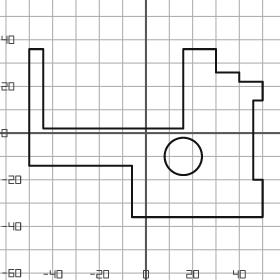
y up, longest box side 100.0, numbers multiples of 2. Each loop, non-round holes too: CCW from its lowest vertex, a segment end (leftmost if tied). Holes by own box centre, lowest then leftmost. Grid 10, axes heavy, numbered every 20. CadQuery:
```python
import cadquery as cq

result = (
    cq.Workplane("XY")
    .moveTo(-6.0, -36.0)
    .lineTo(50.0, -36.0)
    .lineTo(50.0, -20.0)
    .lineTo(46.0, -20.0)
    .lineTo(46.0, 14.0)
    .lineTo(50.0, 14.0)
    .lineTo(50.0, 22.0)
    .lineTo(40.0, 22.0)
    .lineTo(40.0, 26.0)
    .lineTo(30.0, 26.0)
    .lineTo(30.0, 36.0)
    .lineTo(16.0, 36.0)
    .lineTo(16.0, 2.0)
    .lineTo(-44.0, 2.0)
    .lineTo(-44.0, 36.0)
    .lineTo(-50.0, 36.0)
    .lineTo(-50.0, -14.0)
    .lineTo(-6.0, -14.0)
    .close()
    .moveTo(16.0, -10.0)
    .circle(8.0)
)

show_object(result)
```